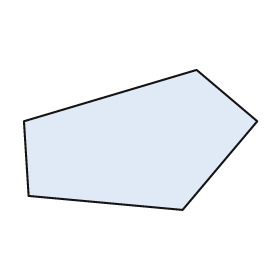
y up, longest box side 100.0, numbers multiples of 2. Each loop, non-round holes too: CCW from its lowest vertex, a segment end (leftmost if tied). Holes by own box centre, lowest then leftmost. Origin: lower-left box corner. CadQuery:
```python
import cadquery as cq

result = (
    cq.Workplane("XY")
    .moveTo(68.0, 0.0)
    .lineTo(100.0, 38.0)
    .lineTo(74.0, 60.0)
    .lineTo(0.0, 38.0)
    .lineTo(2.0, 6.0)
    .close()
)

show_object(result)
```